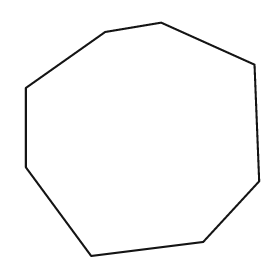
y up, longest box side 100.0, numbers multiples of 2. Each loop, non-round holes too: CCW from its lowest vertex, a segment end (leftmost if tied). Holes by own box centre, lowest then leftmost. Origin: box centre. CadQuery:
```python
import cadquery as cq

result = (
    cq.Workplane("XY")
    .moveTo(-22.0, -50.0)
    .lineTo(26.0, -44.0)
    .lineTo(50.0, -18.0)
    .lineTo(48.0, 32.0)
    .lineTo(8.0, 50.0)
    .lineTo(-16.0, 46.0)
    .lineTo(-50.0, 22.0)
    .lineTo(-50.0, -12.0)
    .close()
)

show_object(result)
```